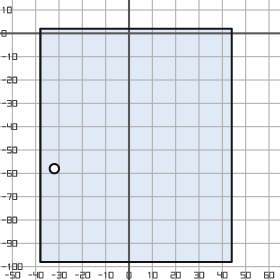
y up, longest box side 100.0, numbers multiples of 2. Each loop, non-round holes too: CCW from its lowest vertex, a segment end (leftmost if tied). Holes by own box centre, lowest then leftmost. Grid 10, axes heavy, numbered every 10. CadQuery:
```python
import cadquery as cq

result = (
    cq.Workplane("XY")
    .moveTo(-38.0, -98.0)
    .lineTo(44.0, -98.0)
    .lineTo(44.0, 2.0)
    .lineTo(-38.0, 2.0)
    .close()
    .moveTo(-32.0, -58.0)
    .circle(2.0)
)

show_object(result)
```